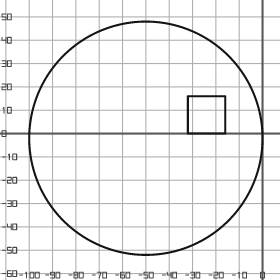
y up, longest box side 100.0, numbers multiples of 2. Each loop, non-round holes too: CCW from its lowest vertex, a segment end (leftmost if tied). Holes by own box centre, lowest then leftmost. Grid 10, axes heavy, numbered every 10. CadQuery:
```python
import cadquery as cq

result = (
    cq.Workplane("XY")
    .moveTo(-50.0, -2.0)
    .circle(50.0)
    .moveTo(-32.0, 0.0)
    .lineTo(-16.0, 0.0)
    .lineTo(-16.0, 16.0)
    .lineTo(-32.0, 16.0)
    .close()
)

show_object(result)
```